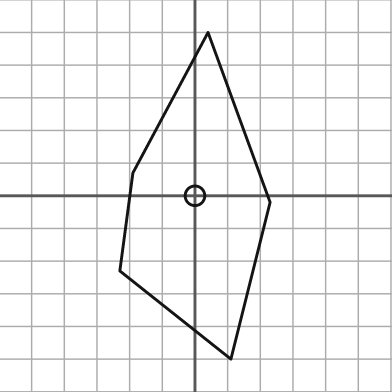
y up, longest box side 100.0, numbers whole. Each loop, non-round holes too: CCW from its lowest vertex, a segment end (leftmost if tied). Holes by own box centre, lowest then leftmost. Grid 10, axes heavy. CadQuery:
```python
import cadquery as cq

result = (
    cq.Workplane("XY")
    .moveTo(11.0, -50.0)
    .lineTo(23.0, -2.0)
    .lineTo(4.0, 50.0)
    .lineTo(-19.0, 7.0)
    .lineTo(-23.0, -23.0)
    .close()
    .moveTo(0.0, 0.0)
    .circle(3.0)
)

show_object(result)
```